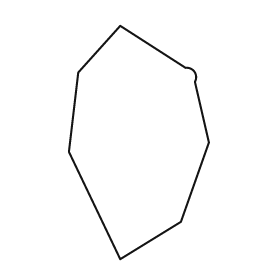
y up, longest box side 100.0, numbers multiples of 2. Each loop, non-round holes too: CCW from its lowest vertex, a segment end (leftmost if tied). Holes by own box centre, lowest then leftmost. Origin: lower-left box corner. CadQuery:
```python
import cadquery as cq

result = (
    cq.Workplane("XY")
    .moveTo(22.0, 0.0)
    .lineTo(48.0, 16.0)
    .lineTo(60.0, 50.0)
    .lineTo(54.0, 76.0)
    .threePointArc((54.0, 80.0), (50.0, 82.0))
    .lineTo(22.0, 100.0)
    .lineTo(4.0, 80.0)
    .lineTo(0.0, 46.0)
    .close()
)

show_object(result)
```